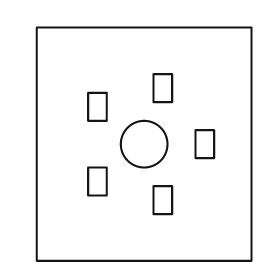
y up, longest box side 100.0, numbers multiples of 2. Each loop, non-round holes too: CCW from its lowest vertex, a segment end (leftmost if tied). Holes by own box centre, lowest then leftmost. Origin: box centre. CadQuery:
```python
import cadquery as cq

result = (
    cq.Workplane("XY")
    .moveTo(-46.0, -50.0)
    .lineTo(46.0, -50.0)
    .lineTo(46.0, 50.0)
    .lineTo(-46.0, 50.0)
    .close()
    .moveTo(4.0, -30.0)
    .lineTo(12.0, -30.0)
    .lineTo(12.0, -18.0)
    .lineTo(4.0, -18.0)
    .close()
    .moveTo(-24.0, -22.0)
    .lineTo(-16.0, -22.0)
    .lineTo(-16.0, -10.0)
    .lineTo(-24.0, -10.0)
    .close()
    .moveTo(0.0, 0.0)
    .circle(10.0)
    .moveTo(22.0, -6.0)
    .lineTo(30.0, -6.0)
    .lineTo(30.0, 6.0)
    .lineTo(22.0, 6.0)
    .close()
    .moveTo(-24.0, 10.0)
    .lineTo(-16.0, 10.0)
    .lineTo(-16.0, 22.0)
    .lineTo(-24.0, 22.0)
    .close()
    .moveTo(4.0, 18.0)
    .lineTo(12.0, 18.0)
    .lineTo(12.0, 30.0)
    .lineTo(4.0, 30.0)
    .close()
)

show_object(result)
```